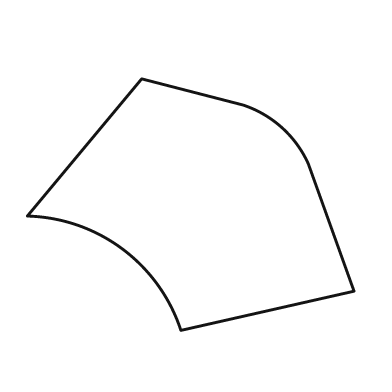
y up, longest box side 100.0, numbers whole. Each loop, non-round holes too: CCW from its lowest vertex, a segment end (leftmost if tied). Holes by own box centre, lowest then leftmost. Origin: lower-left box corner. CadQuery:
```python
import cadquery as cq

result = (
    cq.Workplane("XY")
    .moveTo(47.0, 0.0)
    .lineTo(100.0, 12.0)
    .lineTo(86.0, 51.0)
    .threePointArc((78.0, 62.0), (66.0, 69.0))
    .lineTo(35.0, 77.0)
    .lineTo(0.0, 35.0)
    .threePointArc((29.0, 25.0), (47.0, 0.0))
    .close()
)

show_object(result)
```